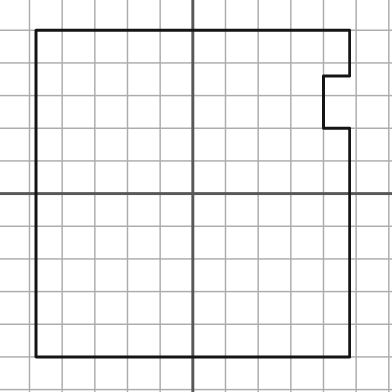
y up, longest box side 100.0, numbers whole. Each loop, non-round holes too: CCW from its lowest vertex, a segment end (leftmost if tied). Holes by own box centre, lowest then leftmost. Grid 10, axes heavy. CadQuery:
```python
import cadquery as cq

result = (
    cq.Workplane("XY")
    .moveTo(-48.0, -50.0)
    .lineTo(48.0, -50.0)
    .lineTo(48.0, 20.0)
    .lineTo(40.0, 20.0)
    .lineTo(40.0, 36.0)
    .lineTo(48.0, 36.0)
    .lineTo(48.0, 50.0)
    .lineTo(-48.0, 50.0)
    .close()
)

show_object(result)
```